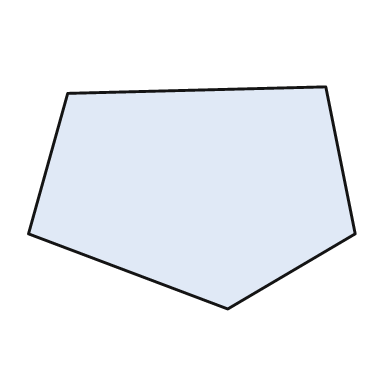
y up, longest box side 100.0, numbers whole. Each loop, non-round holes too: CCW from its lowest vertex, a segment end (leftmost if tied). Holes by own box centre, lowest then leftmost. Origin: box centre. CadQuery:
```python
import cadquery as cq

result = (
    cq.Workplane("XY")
    .moveTo(11.0, -34.0)
    .lineTo(50.0, -11.0)
    .lineTo(41.0, 34.0)
    .lineTo(-38.0, 32.0)
    .lineTo(-50.0, -11.0)
    .close()
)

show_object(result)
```